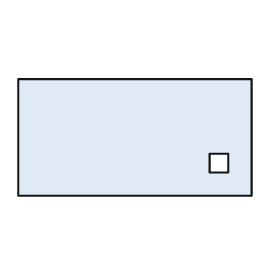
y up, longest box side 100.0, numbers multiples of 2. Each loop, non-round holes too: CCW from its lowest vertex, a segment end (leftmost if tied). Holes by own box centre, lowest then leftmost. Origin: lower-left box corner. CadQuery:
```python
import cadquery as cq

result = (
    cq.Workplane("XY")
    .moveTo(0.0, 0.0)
    .lineTo(100.0, 0.0)
    .lineTo(100.0, 50.0)
    .lineTo(0.0, 50.0)
    .close()
    .moveTo(82.0, 10.0)
    .lineTo(90.0, 10.0)
    .lineTo(90.0, 18.0)
    .lineTo(82.0, 18.0)
    .close()
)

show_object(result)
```